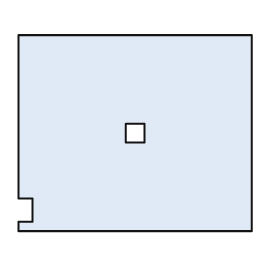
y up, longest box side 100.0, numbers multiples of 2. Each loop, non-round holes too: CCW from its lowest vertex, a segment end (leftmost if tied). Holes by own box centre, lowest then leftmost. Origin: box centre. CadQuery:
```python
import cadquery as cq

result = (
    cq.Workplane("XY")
    .moveTo(-50.0, -42.0)
    .lineTo(50.0, -42.0)
    .lineTo(50.0, 42.0)
    .lineTo(-50.0, 42.0)
    .lineTo(-50.0, -28.0)
    .lineTo(-44.0, -28.0)
    .lineTo(-44.0, -38.0)
    .lineTo(-50.0, -38.0)
    .close()
    .moveTo(-4.0, -4.0)
    .lineTo(4.0, -4.0)
    .lineTo(4.0, 4.0)
    .lineTo(-4.0, 4.0)
    .close()
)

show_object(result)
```